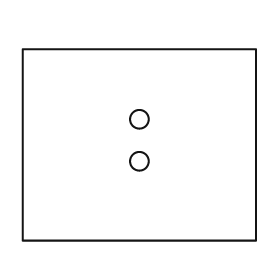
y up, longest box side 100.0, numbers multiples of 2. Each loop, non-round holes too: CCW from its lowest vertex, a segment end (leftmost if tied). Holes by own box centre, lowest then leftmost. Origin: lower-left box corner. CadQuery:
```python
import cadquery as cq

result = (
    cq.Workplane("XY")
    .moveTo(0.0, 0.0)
    .lineTo(100.0, 0.0)
    .lineTo(100.0, 82.0)
    .lineTo(0.0, 82.0)
    .close()
    .moveTo(50.0, 34.0)
    .circle(4.0)
    .moveTo(50.0, 52.0)
    .circle(4.0)
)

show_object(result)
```